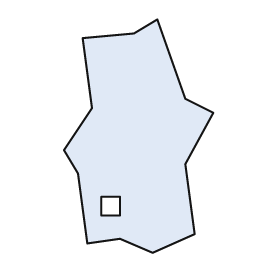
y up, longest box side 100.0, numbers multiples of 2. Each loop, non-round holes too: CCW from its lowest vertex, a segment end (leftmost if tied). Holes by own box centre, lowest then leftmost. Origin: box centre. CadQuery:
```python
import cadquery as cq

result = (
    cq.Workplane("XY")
    .moveTo(6.0, -50.0)
    .lineTo(24.0, -42.0)
    .lineTo(20.0, -12.0)
    .lineTo(32.0, 10.0)
    .lineTo(20.0, 16.0)
    .lineTo(8.0, 50.0)
    .lineTo(-2.0, 44.0)
    .lineTo(-24.0, 42.0)
    .lineTo(-20.0, 12.0)
    .lineTo(-32.0, -6.0)
    .lineTo(-26.0, -16.0)
    .lineTo(-22.0, -46.0)
    .lineTo(-8.0, -44.0)
    .close()
    .moveTo(-16.0, -34.0)
    .lineTo(-8.0, -34.0)
    .lineTo(-8.0, -26.0)
    .lineTo(-16.0, -26.0)
    .close()
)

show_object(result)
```